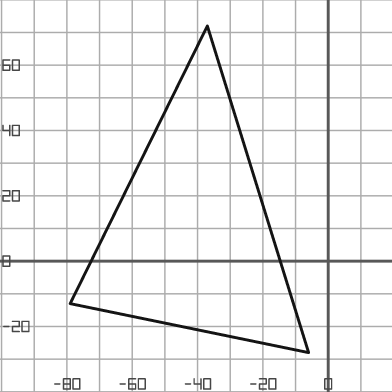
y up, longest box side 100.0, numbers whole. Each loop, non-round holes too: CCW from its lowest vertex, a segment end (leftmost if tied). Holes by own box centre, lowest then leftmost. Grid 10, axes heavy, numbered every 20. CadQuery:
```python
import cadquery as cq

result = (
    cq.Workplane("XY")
    .moveTo(-6.0, -28.0)
    .lineTo(-37.0, 72.0)
    .lineTo(-79.0, -13.0)
    .close()
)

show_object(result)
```